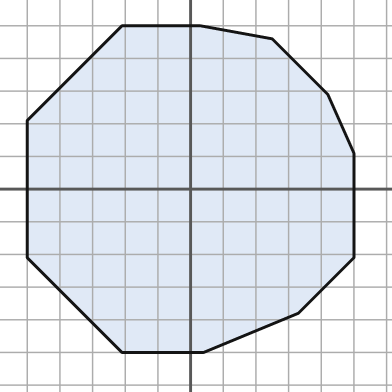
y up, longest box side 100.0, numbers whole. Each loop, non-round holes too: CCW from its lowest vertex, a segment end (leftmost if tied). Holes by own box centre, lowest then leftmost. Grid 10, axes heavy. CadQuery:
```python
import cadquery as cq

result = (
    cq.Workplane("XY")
    .moveTo(-21.0, -50.0)
    .lineTo(4.0, -50.0)
    .lineTo(33.0, -38.0)
    .lineTo(50.0, -21.0)
    .lineTo(50.0, 11.0)
    .lineTo(42.0, 29.0)
    .lineTo(25.0, 46.0)
    .lineTo(3.0, 50.0)
    .lineTo(-21.0, 50.0)
    .lineTo(-50.0, 21.0)
    .lineTo(-50.0, -21.0)
    .close()
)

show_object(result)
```